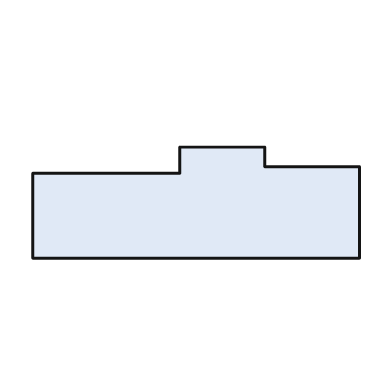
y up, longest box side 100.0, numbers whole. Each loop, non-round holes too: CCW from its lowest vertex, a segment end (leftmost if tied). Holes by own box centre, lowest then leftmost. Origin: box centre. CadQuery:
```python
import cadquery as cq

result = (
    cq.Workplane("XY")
    .moveTo(-50.0, -17.0)
    .lineTo(50.0, -17.0)
    .lineTo(50.0, 11.0)
    .lineTo(21.0, 11.0)
    .lineTo(21.0, 17.0)
    .lineTo(-5.0, 17.0)
    .lineTo(-5.0, 9.0)
    .lineTo(-50.0, 9.0)
    .close()
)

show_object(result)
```